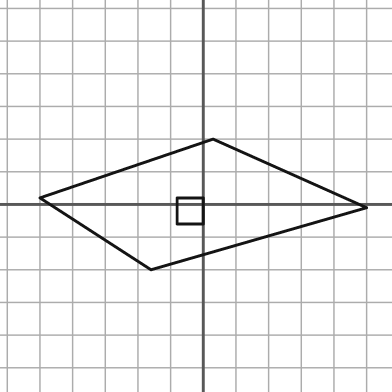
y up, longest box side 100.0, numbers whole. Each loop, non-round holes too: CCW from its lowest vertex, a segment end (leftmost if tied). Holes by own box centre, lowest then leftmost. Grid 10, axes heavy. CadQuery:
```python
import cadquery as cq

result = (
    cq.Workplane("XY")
    .moveTo(-16.0, -20.0)
    .lineTo(50.0, -1.0)
    .lineTo(3.0, 20.0)
    .lineTo(-50.0, 2.0)
    .close()
    .moveTo(-8.0, -6.0)
    .lineTo(0.0, -6.0)
    .lineTo(0.0, 2.0)
    .lineTo(-8.0, 2.0)
    .close()
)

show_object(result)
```